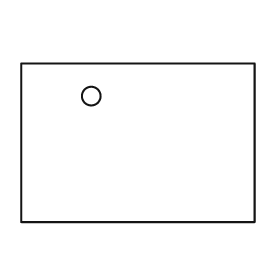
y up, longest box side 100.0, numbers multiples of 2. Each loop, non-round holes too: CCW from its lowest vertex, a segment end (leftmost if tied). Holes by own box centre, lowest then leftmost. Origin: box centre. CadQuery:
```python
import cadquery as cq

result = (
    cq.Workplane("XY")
    .moveTo(-50.0, -34.0)
    .lineTo(50.0, -34.0)
    .lineTo(50.0, 34.0)
    .lineTo(-50.0, 34.0)
    .close()
    .moveTo(-20.0, 20.0)
    .circle(4.0)
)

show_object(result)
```